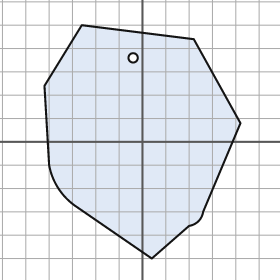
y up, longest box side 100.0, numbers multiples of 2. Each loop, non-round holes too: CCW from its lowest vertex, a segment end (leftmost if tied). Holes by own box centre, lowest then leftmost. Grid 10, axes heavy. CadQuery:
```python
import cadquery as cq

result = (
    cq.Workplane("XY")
    .moveTo(4.0, -50.0)
    .lineTo(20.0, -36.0)
    .threePointArc((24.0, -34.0), (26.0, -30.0))
    .lineTo(42.0, 8.0)
    .lineTo(22.0, 44.0)
    .lineTo(-26.0, 50.0)
    .lineTo(-42.0, 24.0)
    .lineTo(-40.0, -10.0)
    .threePointArc((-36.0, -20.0), (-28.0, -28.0))
    .close()
    .moveTo(-4.0, 36.0)
    .circle(2.0)
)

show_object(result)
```